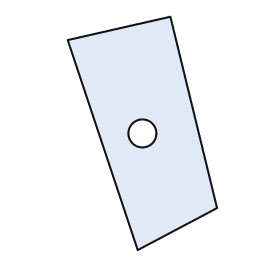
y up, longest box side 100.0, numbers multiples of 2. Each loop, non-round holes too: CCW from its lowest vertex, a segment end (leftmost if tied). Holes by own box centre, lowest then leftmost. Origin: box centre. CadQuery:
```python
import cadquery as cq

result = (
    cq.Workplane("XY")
    .moveTo(-2.0, -50.0)
    .lineTo(32.0, -32.0)
    .lineTo(12.0, 50.0)
    .lineTo(-32.0, 40.0)
    .close()
    .moveTo(0.0, 0.0)
    .circle(6.0)
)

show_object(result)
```